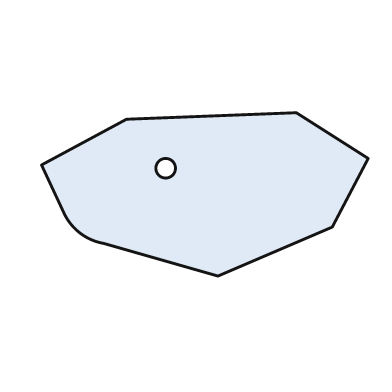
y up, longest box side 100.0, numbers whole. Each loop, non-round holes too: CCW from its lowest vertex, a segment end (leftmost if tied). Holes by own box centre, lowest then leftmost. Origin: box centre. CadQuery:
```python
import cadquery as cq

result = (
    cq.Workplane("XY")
    .moveTo(4.0, -25.0)
    .lineTo(39.0, -10.0)
    .lineTo(50.0, 11.0)
    .lineTo(28.0, 25.0)
    .lineTo(-24.0, 23.0)
    .lineTo(-50.0, 9.0)
    .lineTo(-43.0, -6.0)
    .threePointArc((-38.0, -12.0), (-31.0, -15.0))
    .close()
    .moveTo(-12.0, 8.0)
    .circle(3.0)
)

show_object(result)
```